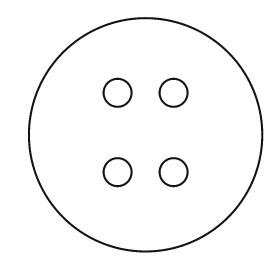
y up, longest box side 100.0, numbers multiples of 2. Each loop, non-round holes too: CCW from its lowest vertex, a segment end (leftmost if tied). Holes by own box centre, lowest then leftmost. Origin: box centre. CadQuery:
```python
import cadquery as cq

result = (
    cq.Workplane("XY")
    .moveTo(0.0, 0.0)
    .circle(50.0)
    .moveTo(-12.0, -16.0)
    .circle(6.0)
    .moveTo(12.0, -16.0)
    .circle(6.0)
    .moveTo(-12.0, 18.0)
    .circle(6.0)
    .moveTo(12.0, 18.0)
    .circle(6.0)
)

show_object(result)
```